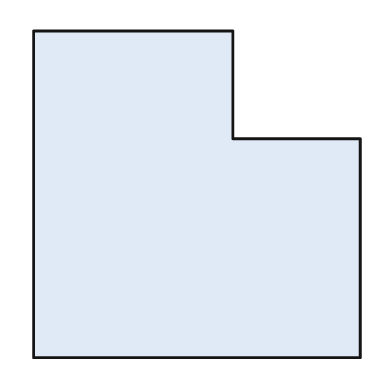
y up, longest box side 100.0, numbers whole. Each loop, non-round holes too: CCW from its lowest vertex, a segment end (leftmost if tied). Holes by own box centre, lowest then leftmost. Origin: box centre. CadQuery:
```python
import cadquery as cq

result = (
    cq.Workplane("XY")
    .moveTo(-50.0, -50.0)
    .lineTo(50.0, -50.0)
    .lineTo(50.0, 17.0)
    .lineTo(11.0, 17.0)
    .lineTo(11.0, 50.0)
    .lineTo(-50.0, 50.0)
    .close()
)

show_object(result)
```